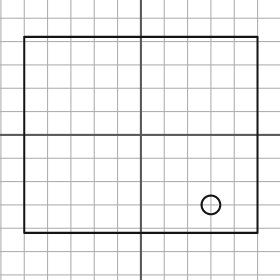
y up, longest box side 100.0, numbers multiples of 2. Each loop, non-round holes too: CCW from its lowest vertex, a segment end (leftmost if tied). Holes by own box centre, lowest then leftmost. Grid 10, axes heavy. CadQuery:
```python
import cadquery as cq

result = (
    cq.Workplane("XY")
    .moveTo(-50.0, -42.0)
    .lineTo(50.0, -42.0)
    .lineTo(50.0, 42.0)
    .lineTo(-50.0, 42.0)
    .close()
    .moveTo(30.0, -30.0)
    .circle(4.0)
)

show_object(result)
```